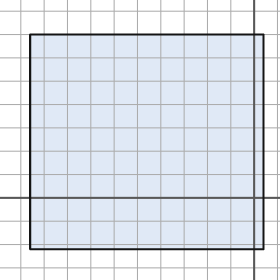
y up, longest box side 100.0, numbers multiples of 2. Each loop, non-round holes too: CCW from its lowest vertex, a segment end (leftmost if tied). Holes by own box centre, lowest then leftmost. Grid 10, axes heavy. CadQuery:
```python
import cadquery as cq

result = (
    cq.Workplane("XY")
    .moveTo(-96.0, -22.0)
    .lineTo(4.0, -22.0)
    .lineTo(4.0, 70.0)
    .lineTo(-96.0, 70.0)
    .close()
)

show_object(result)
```